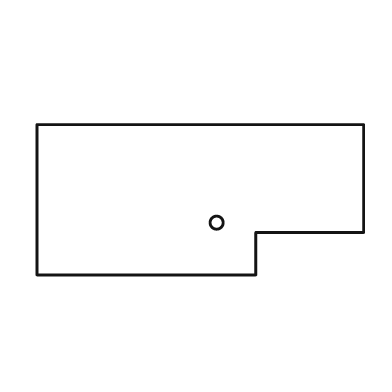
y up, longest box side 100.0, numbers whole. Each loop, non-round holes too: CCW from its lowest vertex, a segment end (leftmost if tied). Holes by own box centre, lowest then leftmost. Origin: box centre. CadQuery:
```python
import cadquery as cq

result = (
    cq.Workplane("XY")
    .moveTo(-50.0, -23.0)
    .lineTo(17.0, -23.0)
    .lineTo(17.0, -10.0)
    .lineTo(50.0, -10.0)
    .lineTo(50.0, 23.0)
    .lineTo(-50.0, 23.0)
    .close()
    .moveTo(5.0, -7.0)
    .circle(2.0)
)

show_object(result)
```